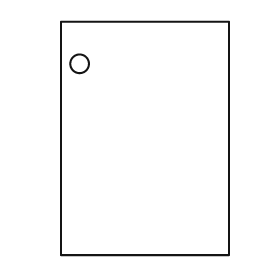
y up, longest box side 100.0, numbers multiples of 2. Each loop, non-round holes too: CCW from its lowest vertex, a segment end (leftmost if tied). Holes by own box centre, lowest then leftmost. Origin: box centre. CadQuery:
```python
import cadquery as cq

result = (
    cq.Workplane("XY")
    .moveTo(-36.0, -50.0)
    .lineTo(36.0, -50.0)
    .lineTo(36.0, 50.0)
    .lineTo(-36.0, 50.0)
    .close()
    .moveTo(-28.0, 32.0)
    .circle(4.0)
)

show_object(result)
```